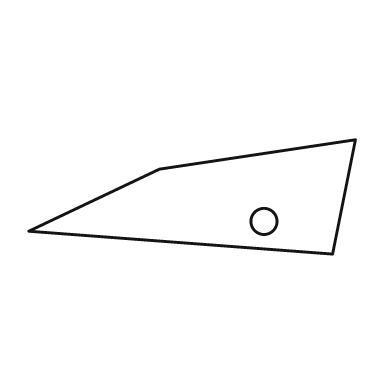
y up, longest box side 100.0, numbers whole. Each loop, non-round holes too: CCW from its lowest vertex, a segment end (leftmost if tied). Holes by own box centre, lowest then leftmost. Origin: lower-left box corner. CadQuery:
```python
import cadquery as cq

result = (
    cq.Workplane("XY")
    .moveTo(93.0, 0.0)
    .lineTo(100.0, 35.0)
    .lineTo(40.0, 26.0)
    .lineTo(0.0, 7.0)
    .close()
    .moveTo(72.0, 10.0)
    .circle(4.0)
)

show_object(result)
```